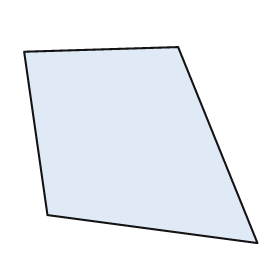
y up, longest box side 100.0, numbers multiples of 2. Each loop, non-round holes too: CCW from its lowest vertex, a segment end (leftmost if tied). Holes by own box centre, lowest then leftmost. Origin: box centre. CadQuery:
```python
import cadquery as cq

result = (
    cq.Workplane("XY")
    .moveTo(50.0, -42.0)
    .lineTo(16.0, 42.0)
    .lineTo(-50.0, 40.0)
    .lineTo(-40.0, -30.0)
    .close()
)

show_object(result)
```